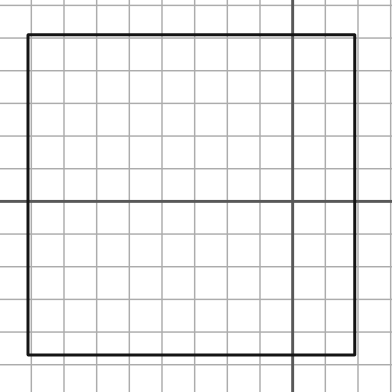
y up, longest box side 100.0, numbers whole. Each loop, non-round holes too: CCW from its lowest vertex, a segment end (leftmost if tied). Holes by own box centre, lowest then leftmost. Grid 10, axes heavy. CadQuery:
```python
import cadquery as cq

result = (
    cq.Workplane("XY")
    .moveTo(-81.0, -47.0)
    .lineTo(19.0, -47.0)
    .lineTo(19.0, 51.0)
    .lineTo(-81.0, 51.0)
    .close()
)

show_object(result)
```